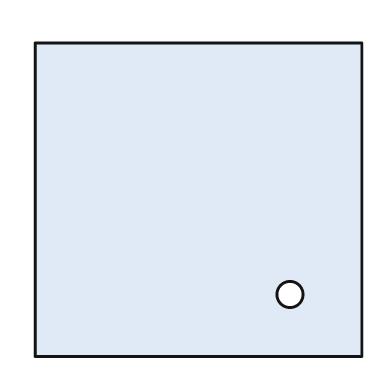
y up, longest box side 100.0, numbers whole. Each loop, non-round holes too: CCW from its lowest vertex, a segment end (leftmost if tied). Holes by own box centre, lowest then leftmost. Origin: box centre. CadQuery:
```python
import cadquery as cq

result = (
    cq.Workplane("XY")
    .moveTo(-50.0, -48.0)
    .lineTo(50.0, -48.0)
    .lineTo(50.0, 48.0)
    .lineTo(-50.0, 48.0)
    .close()
    .moveTo(28.0, -29.0)
    .circle(4.0)
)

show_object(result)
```